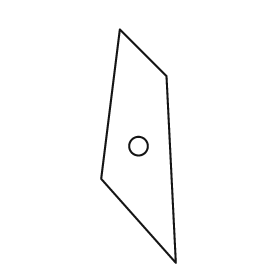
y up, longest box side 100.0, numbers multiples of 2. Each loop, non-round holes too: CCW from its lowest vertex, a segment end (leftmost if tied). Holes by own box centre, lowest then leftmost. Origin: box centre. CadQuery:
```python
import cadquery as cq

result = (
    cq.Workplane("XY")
    .moveTo(16.0, -50.0)
    .lineTo(12.0, 30.0)
    .lineTo(-8.0, 50.0)
    .lineTo(-16.0, -14.0)
    .close()
    .moveTo(0.0, 0.0)
    .circle(4.0)
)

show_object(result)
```